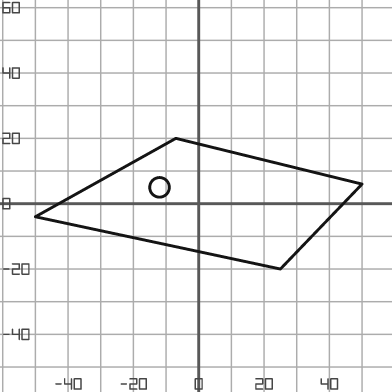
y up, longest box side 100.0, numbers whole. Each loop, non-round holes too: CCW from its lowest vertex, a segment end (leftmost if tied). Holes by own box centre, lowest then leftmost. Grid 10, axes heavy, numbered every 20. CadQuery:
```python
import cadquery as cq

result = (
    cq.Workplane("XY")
    .moveTo(25.0, -20.0)
    .lineTo(50.0, 6.0)
    .lineTo(-7.0, 20.0)
    .lineTo(-50.0, -4.0)
    .close()
    .moveTo(-12.0, 5.0)
    .circle(3.0)
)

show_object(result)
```